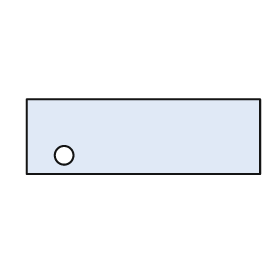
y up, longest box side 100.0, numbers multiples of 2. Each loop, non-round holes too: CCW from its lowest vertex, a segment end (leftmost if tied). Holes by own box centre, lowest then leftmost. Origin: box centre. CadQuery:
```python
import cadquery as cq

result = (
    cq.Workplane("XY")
    .moveTo(-50.0, -16.0)
    .lineTo(50.0, -16.0)
    .lineTo(50.0, 16.0)
    .lineTo(-50.0, 16.0)
    .close()
    .moveTo(-34.0, -8.0)
    .circle(4.0)
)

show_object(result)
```